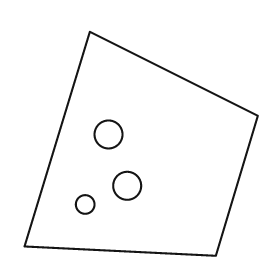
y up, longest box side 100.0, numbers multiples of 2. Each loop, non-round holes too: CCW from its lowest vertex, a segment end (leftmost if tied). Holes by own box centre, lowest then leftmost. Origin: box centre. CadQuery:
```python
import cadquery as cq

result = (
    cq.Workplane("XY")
    .moveTo(32.0, -48.0)
    .lineTo(50.0, 12.0)
    .lineTo(-22.0, 48.0)
    .lineTo(-50.0, -44.0)
    .close()
    .moveTo(-24.0, -26.0)
    .circle(4.0)
    .moveTo(-6.0, -18.0)
    .circle(6.0)
    .moveTo(-14.0, 4.0)
    .circle(6.0)
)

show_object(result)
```